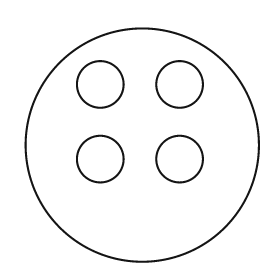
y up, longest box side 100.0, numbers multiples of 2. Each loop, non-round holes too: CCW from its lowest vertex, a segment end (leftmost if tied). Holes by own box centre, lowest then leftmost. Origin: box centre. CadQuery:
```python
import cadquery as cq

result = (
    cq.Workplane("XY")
    .moveTo(0.0, 0.0)
    .circle(50.0)
    .moveTo(-18.0, -6.0)
    .circle(10.0)
    .moveTo(16.0, -6.0)
    .circle(10.0)
    .moveTo(-18.0, 26.0)
    .circle(10.0)
    .moveTo(16.0, 26.0)
    .circle(10.0)
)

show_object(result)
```